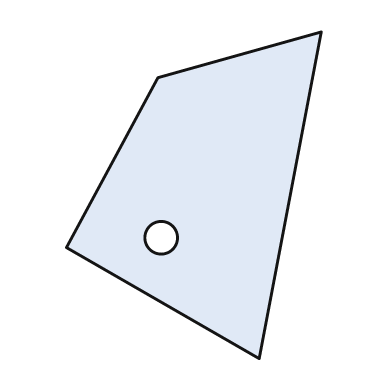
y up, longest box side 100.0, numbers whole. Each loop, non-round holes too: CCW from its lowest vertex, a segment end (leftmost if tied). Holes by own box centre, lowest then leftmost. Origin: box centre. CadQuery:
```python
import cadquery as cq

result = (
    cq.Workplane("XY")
    .moveTo(20.0, -50.0)
    .lineTo(39.0, 50.0)
    .lineTo(-11.0, 36.0)
    .lineTo(-39.0, -16.0)
    .close()
    .moveTo(-10.0, -13.0)
    .circle(5.0)
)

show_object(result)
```